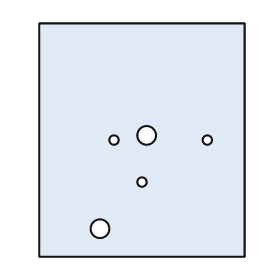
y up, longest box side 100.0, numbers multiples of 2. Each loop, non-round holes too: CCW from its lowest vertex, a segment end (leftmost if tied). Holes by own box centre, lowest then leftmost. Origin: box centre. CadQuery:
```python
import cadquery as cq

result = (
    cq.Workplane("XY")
    .moveTo(-44.0, -50.0)
    .lineTo(44.0, -50.0)
    .lineTo(44.0, 50.0)
    .lineTo(-44.0, 50.0)
    .close()
    .moveTo(-18.0, -38.0)
    .circle(4.0)
    .moveTo(0.0, -18.0)
    .circle(2.0)
    .moveTo(-12.0, 0.0)
    .circle(2.0)
    .moveTo(28.0, 0.0)
    .circle(2.0)
    .moveTo(2.0, 2.0)
    .circle(4.0)
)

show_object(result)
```